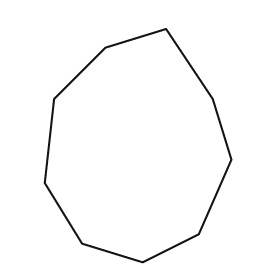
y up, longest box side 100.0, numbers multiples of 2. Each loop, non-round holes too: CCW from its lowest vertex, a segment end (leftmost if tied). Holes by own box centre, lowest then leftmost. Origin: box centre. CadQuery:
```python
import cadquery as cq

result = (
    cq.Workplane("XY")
    .moveTo(2.0, -50.0)
    .lineTo(26.0, -38.0)
    .lineTo(40.0, -6.0)
    .lineTo(32.0, 20.0)
    .lineTo(12.0, 50.0)
    .lineTo(-14.0, 42.0)
    .lineTo(-36.0, 20.0)
    .lineTo(-40.0, -16.0)
    .lineTo(-24.0, -42.0)
    .close()
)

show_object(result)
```